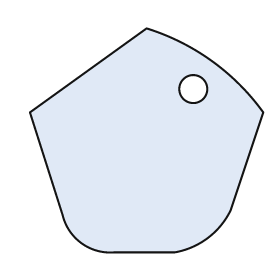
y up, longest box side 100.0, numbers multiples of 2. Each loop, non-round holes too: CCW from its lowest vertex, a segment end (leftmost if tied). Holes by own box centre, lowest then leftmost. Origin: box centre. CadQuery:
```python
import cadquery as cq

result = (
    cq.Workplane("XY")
    .moveTo(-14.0, -48.0)
    .lineTo(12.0, -48.0)
    .threePointArc((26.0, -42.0), (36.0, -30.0))
    .lineTo(50.0, 12.0)
    .threePointArc((28.0, 34.0), (0.0, 48.0))
    .lineTo(-50.0, 12.0)
    .lineTo(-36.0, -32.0)
    .threePointArc((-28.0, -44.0), (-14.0, -48.0))
    .close()
    .moveTo(20.0, 22.0)
    .circle(6.0)
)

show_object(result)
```